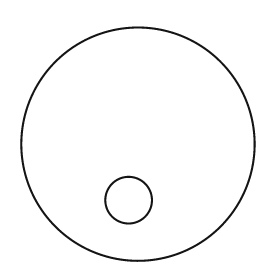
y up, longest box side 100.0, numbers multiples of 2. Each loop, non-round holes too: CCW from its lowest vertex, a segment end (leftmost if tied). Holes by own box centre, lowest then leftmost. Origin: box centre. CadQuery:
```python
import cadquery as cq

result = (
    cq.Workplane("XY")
    .moveTo(0.0, 0.0)
    .circle(50.0)
    .moveTo(-4.0, -24.0)
    .circle(10.0)
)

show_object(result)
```